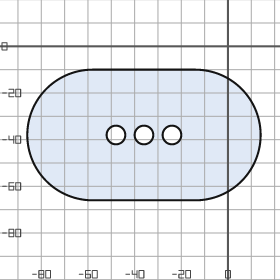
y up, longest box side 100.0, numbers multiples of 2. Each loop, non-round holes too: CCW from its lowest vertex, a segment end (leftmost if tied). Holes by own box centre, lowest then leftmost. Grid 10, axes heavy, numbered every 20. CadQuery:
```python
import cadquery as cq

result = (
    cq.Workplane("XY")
    .moveTo(-58.0, -66.0)
    .lineTo(-14.0, -66.0)
    .threePointArc((14.0, -38.0), (-14.0, -10.0))
    .lineTo(-58.0, -10.0)
    .threePointArc((-86.0, -38.0), (-58.0, -66.0))
    .close()
    .moveTo(-48.0, -38.0)
    .circle(4.0)
    .moveTo(-36.0, -38.0)
    .circle(4.0)
    .moveTo(-24.0, -38.0)
    .circle(4.0)
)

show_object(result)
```